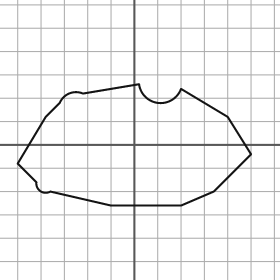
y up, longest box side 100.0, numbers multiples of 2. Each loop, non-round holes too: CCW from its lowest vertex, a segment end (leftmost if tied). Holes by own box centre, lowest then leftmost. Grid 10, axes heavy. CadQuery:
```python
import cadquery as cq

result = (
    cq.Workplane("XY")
    .moveTo(-10.0, -26.0)
    .lineTo(20.0, -26.0)
    .lineTo(34.0, -20.0)
    .lineTo(50.0, -4.0)
    .lineTo(40.0, 12.0)
    .lineTo(20.0, 24.0)
    .threePointArc((10.0, 18.0), (2.0, 26.0))
    .lineTo(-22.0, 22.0)
    .threePointArc((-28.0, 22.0), (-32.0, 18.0))
    .lineTo(-38.0, 12.0)
    .lineTo(-50.0, -8.0)
    .lineTo(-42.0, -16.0)
    .threePointArc((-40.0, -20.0), (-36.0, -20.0))
    .close()
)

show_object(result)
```